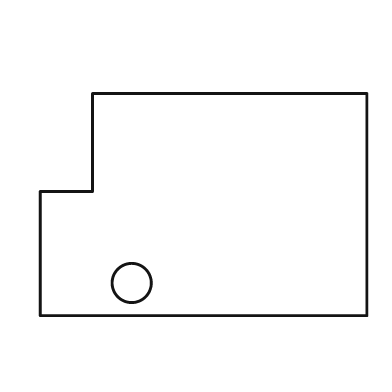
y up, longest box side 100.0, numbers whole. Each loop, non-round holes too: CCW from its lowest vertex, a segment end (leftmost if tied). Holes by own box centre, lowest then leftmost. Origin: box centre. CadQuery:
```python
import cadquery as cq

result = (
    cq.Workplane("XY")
    .moveTo(-50.0, -34.0)
    .lineTo(50.0, -34.0)
    .lineTo(50.0, 34.0)
    .lineTo(-34.0, 34.0)
    .lineTo(-34.0, 4.0)
    .lineTo(-50.0, 4.0)
    .close()
    .moveTo(-22.0, -24.0)
    .circle(6.0)
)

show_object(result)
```